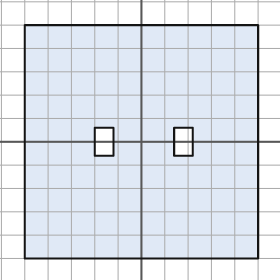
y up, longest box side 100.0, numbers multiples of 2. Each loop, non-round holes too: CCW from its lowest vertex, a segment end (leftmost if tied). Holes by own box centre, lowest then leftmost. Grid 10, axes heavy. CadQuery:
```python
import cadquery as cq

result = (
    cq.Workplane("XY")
    .moveTo(-50.0, -50.0)
    .lineTo(50.0, -50.0)
    .lineTo(50.0, 50.0)
    .lineTo(-50.0, 50.0)
    .close()
    .moveTo(-20.0, -6.0)
    .lineTo(-12.0, -6.0)
    .lineTo(-12.0, 6.0)
    .lineTo(-20.0, 6.0)
    .close()
    .moveTo(14.0, -6.0)
    .lineTo(22.0, -6.0)
    .lineTo(22.0, 6.0)
    .lineTo(14.0, 6.0)
    .close()
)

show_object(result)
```